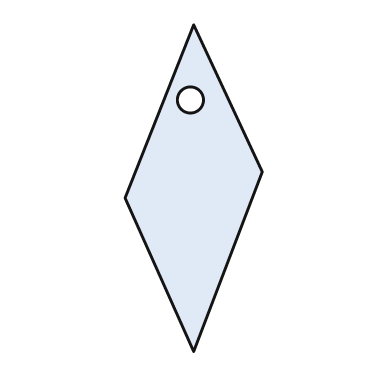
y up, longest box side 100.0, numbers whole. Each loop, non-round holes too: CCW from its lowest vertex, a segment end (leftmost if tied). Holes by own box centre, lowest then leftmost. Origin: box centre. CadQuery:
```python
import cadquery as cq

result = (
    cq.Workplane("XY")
    .moveTo(0.0, -50.0)
    .lineTo(21.0, 5.0)
    .lineTo(0.0, 50.0)
    .lineTo(-21.0, -3.0)
    .close()
    .moveTo(-1.0, 27.0)
    .circle(4.0)
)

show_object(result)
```